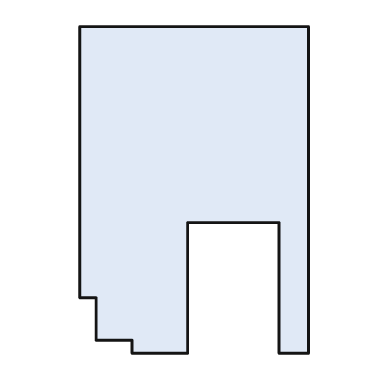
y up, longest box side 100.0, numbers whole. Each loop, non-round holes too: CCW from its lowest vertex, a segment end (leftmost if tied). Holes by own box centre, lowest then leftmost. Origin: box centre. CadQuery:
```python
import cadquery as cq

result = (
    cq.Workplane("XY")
    .moveTo(-19.0, -50.0)
    .lineTo(-2.0, -50.0)
    .lineTo(-2.0, -10.0)
    .lineTo(26.0, -10.0)
    .lineTo(26.0, -50.0)
    .lineTo(35.0, -50.0)
    .lineTo(35.0, 50.0)
    .lineTo(-35.0, 50.0)
    .lineTo(-35.0, -33.0)
    .lineTo(-30.0, -33.0)
    .lineTo(-30.0, -46.0)
    .lineTo(-19.0, -46.0)
    .close()
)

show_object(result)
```